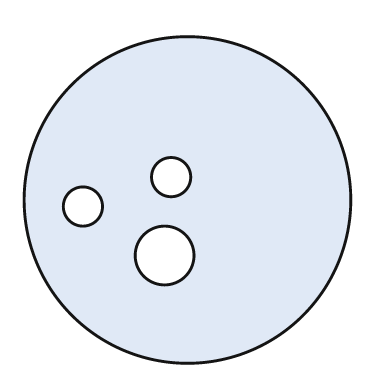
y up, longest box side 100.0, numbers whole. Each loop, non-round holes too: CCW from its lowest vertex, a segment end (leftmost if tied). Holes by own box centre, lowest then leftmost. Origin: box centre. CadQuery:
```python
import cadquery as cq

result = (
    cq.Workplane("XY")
    .moveTo(0.0, 0.0)
    .circle(50.0)
    .moveTo(-7.0, -17.0)
    .circle(9.0)
    .moveTo(-32.0, -2.0)
    .circle(6.0)
    .moveTo(-5.0, 7.0)
    .circle(6.0)
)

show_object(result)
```